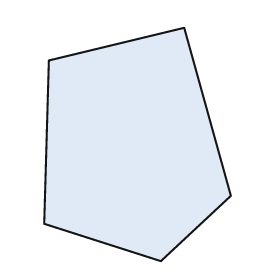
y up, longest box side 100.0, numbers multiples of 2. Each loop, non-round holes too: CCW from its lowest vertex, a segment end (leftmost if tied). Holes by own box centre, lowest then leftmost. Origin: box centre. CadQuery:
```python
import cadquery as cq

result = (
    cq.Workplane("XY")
    .moveTo(10.0, -50.0)
    .lineTo(40.0, -22.0)
    .lineTo(20.0, 50.0)
    .lineTo(-38.0, 36.0)
    .lineTo(-40.0, -34.0)
    .close()
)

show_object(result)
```